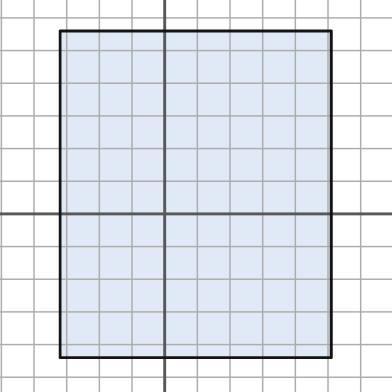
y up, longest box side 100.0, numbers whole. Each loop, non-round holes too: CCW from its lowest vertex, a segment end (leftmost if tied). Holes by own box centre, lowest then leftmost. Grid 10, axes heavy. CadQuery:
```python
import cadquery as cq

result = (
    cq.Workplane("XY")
    .moveTo(-32.0, -44.0)
    .lineTo(51.0, -44.0)
    .lineTo(51.0, 56.0)
    .lineTo(-32.0, 56.0)
    .close()
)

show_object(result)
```